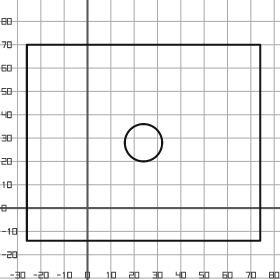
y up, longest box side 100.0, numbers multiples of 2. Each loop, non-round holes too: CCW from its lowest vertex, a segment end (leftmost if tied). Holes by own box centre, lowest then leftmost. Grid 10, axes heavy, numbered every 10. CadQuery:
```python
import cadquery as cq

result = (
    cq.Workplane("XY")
    .moveTo(-26.0, -14.0)
    .lineTo(74.0, -14.0)
    .lineTo(74.0, 70.0)
    .lineTo(-26.0, 70.0)
    .close()
    .moveTo(24.0, 28.0)
    .circle(8.0)
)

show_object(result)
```